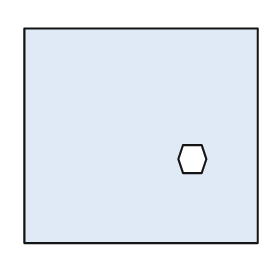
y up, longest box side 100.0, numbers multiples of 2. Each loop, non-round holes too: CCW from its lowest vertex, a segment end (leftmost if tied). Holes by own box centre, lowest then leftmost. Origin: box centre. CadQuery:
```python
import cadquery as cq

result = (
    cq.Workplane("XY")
    .moveTo(-50.0, -46.0)
    .lineTo(50.0, -46.0)
    .lineTo(50.0, 46.0)
    .lineTo(-50.0, 46.0)
    .close()
    .moveTo(18.0, -16.0)
    .lineTo(26.0, -16.0)
    .lineTo(28.0, -10.0)
    .lineTo(26.0, -4.0)
    .lineTo(18.0, -4.0)
    .lineTo(16.0, -10.0)
    .close()
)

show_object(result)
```